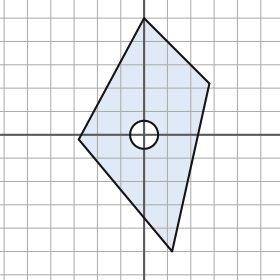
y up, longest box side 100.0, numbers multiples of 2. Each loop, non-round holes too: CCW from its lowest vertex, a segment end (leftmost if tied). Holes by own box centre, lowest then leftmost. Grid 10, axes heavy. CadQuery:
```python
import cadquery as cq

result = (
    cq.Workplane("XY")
    .moveTo(12.0, -50.0)
    .lineTo(28.0, 22.0)
    .lineTo(0.0, 50.0)
    .lineTo(-28.0, -2.0)
    .close()
    .moveTo(0.0, 0.0)
    .circle(6.0)
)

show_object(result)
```